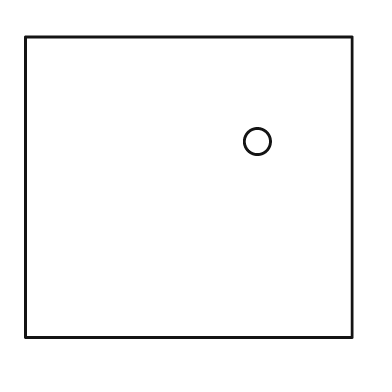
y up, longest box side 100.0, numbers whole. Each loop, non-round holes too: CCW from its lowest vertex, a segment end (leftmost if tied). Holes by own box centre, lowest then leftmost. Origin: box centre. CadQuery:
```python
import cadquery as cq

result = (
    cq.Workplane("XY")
    .moveTo(-50.0, -46.0)
    .lineTo(50.0, -46.0)
    .lineTo(50.0, 46.0)
    .lineTo(-50.0, 46.0)
    .close()
    .moveTo(21.0, 14.0)
    .circle(4.0)
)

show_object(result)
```